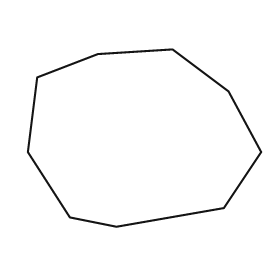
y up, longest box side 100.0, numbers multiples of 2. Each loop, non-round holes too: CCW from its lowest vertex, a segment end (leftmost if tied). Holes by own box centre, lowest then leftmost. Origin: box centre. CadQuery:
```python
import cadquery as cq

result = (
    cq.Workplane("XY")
    .moveTo(-12.0, -38.0)
    .lineTo(34.0, -30.0)
    .lineTo(50.0, -6.0)
    .lineTo(36.0, 20.0)
    .lineTo(12.0, 38.0)
    .lineTo(-20.0, 36.0)
    .lineTo(-46.0, 26.0)
    .lineTo(-50.0, -6.0)
    .lineTo(-32.0, -34.0)
    .close()
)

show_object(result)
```